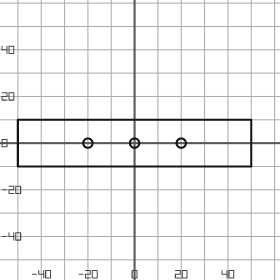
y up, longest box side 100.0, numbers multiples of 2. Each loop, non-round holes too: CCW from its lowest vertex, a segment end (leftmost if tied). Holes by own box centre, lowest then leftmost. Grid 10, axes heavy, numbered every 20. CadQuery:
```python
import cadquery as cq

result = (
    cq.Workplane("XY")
    .moveTo(-50.0, -10.0)
    .lineTo(50.0, -10.0)
    .lineTo(50.0, 10.0)
    .lineTo(-50.0, 10.0)
    .close()
    .moveTo(-20.0, 0.0)
    .circle(2.0)
    .moveTo(0.0, 0.0)
    .circle(2.0)
    .moveTo(20.0, 0.0)
    .circle(2.0)
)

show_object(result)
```